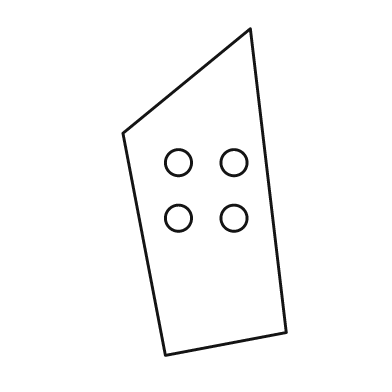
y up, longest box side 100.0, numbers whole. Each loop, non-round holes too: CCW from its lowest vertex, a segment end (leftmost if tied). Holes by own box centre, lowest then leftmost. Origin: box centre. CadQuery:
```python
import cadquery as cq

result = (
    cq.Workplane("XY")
    .moveTo(-12.0, -50.0)
    .lineTo(25.0, -43.0)
    .lineTo(14.0, 50.0)
    .lineTo(-25.0, 18.0)
    .close()
    .moveTo(-8.0, -8.0)
    .circle(4.0)
    .moveTo(9.0, -8.0)
    .circle(4.0)
    .moveTo(-8.0, 9.0)
    .circle(4.0)
    .moveTo(9.0, 9.0)
    .circle(4.0)
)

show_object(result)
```